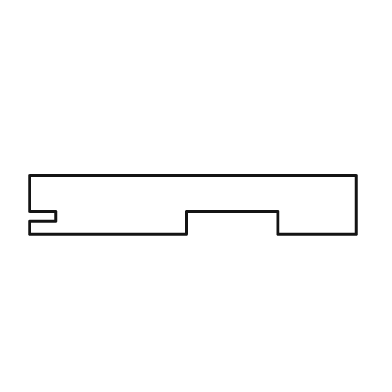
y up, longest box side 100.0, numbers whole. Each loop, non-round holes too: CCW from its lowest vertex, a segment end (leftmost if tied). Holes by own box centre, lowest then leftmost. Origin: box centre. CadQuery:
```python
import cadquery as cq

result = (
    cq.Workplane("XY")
    .moveTo(-50.0, -9.0)
    .lineTo(-2.0, -9.0)
    .lineTo(-2.0, -2.0)
    .lineTo(26.0, -2.0)
    .lineTo(26.0, -9.0)
    .lineTo(50.0, -9.0)
    .lineTo(50.0, 9.0)
    .lineTo(-50.0, 9.0)
    .lineTo(-50.0, -2.0)
    .lineTo(-42.0, -2.0)
    .lineTo(-42.0, -5.0)
    .lineTo(-50.0, -5.0)
    .close()
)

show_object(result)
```